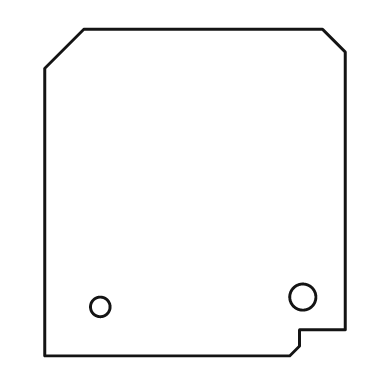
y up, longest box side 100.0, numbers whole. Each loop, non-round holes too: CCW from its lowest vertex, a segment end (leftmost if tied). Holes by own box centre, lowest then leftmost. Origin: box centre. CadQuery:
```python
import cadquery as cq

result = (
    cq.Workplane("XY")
    .moveTo(-46.0, -50.0)
    .lineTo(29.0, -50.0)
    .lineTo(32.0, -47.0)
    .lineTo(32.0, -42.0)
    .lineTo(46.0, -42.0)
    .lineTo(46.0, 43.0)
    .lineTo(39.0, 50.0)
    .lineTo(-34.0, 50.0)
    .lineTo(-46.0, 38.0)
    .close()
    .moveTo(-29.0, -35.0)
    .circle(3.0)
    .moveTo(33.0, -32.0)
    .circle(4.0)
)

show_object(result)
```